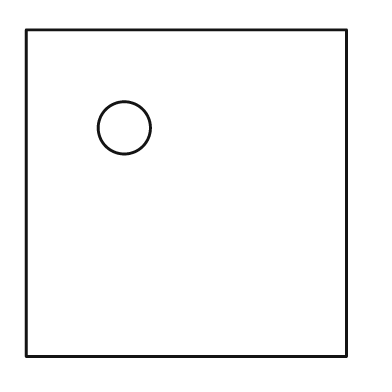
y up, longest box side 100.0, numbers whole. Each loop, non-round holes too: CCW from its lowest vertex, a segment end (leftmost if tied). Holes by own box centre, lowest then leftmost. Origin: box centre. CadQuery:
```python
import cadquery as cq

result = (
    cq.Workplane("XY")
    .moveTo(-49.0, -50.0)
    .lineTo(49.0, -50.0)
    .lineTo(49.0, 50.0)
    .lineTo(-49.0, 50.0)
    .close()
    .moveTo(-19.0, 20.0)
    .circle(8.0)
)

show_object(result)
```